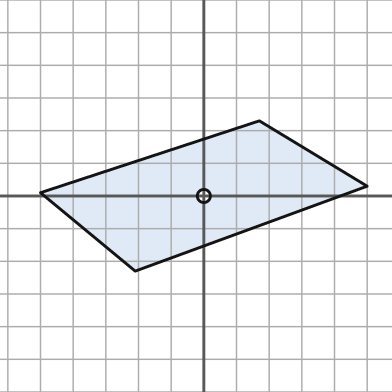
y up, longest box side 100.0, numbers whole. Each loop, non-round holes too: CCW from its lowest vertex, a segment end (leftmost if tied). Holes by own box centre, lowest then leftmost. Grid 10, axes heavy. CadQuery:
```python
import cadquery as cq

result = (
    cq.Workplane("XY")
    .moveTo(-21.0, -23.0)
    .lineTo(50.0, 3.0)
    .lineTo(17.0, 23.0)
    .lineTo(-50.0, 1.0)
    .close()
    .moveTo(0.0, 0.0)
    .circle(2.0)
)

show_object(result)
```